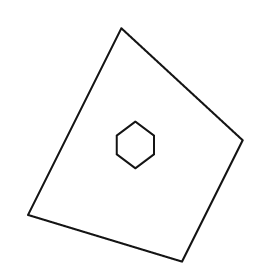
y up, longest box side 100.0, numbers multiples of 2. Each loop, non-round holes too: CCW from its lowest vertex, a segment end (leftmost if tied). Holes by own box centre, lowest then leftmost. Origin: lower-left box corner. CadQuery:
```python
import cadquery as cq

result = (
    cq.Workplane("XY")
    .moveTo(66.0, 0.0)
    .lineTo(92.0, 52.0)
    .lineTo(40.0, 100.0)
    .lineTo(0.0, 20.0)
    .close()
    .moveTo(46.0, 40.0)
    .lineTo(54.0, 46.0)
    .lineTo(54.0, 54.0)
    .lineTo(46.0, 60.0)
    .lineTo(38.0, 54.0)
    .lineTo(38.0, 46.0)
    .close()
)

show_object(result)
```